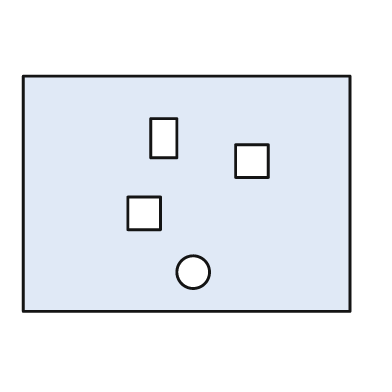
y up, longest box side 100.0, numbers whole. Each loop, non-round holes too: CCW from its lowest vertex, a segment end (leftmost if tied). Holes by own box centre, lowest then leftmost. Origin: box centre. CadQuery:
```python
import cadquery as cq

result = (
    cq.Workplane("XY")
    .moveTo(-50.0, -36.0)
    .lineTo(50.0, -36.0)
    .lineTo(50.0, 36.0)
    .lineTo(-50.0, 36.0)
    .close()
    .moveTo(2.0, -24.0)
    .circle(5.0)
    .moveTo(-18.0, -11.0)
    .lineTo(-8.0, -11.0)
    .lineTo(-8.0, -1.0)
    .lineTo(-18.0, -1.0)
    .close()
    .moveTo(15.0, 5.0)
    .lineTo(25.0, 5.0)
    .lineTo(25.0, 15.0)
    .lineTo(15.0, 15.0)
    .close()
    .moveTo(-11.0, 11.0)
    .lineTo(-3.0, 11.0)
    .lineTo(-3.0, 23.0)
    .lineTo(-11.0, 23.0)
    .close()
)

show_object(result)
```